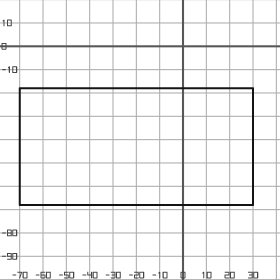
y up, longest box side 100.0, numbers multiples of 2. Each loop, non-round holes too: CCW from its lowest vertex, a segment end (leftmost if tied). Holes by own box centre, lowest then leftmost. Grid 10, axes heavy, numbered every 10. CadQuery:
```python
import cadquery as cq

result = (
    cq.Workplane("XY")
    .moveTo(-70.0, -68.0)
    .lineTo(30.0, -68.0)
    .lineTo(30.0, -18.0)
    .lineTo(-70.0, -18.0)
    .close()
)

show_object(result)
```